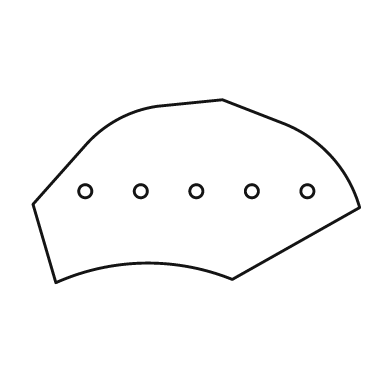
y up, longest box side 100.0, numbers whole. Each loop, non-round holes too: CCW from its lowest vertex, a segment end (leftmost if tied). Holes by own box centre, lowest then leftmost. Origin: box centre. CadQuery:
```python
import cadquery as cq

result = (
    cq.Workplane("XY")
    .moveTo(-43.0, -28.0)
    .threePointArc((-16.0, -22.0), (11.0, -27.0))
    .lineTo(50.0, -5.0)
    .threePointArc((41.0, 11.0), (26.0, 21.0))
    .lineTo(8.0, 28.0)
    .lineTo(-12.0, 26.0)
    .threePointArc((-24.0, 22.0), (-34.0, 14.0))
    .lineTo(-50.0, -4.0)
    .close()
    .moveTo(-34.0, 0.0)
    .circle(2.0)
    .moveTo(-17.0, 0.0)
    .circle(2.0)
    .moveTo(0.0, 0.0)
    .circle(2.0)
    .moveTo(17.0, 0.0)
    .circle(2.0)
    .moveTo(34.0, 0.0)
    .circle(2.0)
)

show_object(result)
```